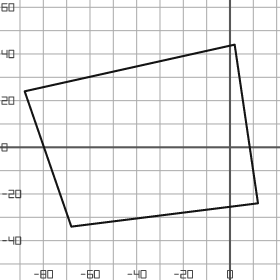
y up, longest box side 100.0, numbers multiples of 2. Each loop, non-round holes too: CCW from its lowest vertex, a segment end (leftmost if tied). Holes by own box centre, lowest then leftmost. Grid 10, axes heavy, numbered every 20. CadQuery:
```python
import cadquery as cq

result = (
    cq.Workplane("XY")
    .moveTo(-68.0, -34.0)
    .lineTo(12.0, -24.0)
    .lineTo(2.0, 44.0)
    .lineTo(-88.0, 24.0)
    .close()
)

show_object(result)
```